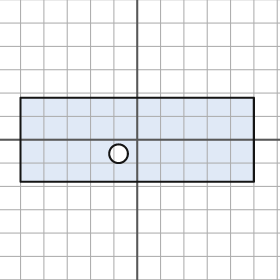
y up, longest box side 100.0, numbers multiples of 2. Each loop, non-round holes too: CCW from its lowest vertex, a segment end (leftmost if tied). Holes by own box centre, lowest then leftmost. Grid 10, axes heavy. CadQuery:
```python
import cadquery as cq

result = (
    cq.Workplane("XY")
    .moveTo(-50.0, -18.0)
    .lineTo(50.0, -18.0)
    .lineTo(50.0, 18.0)
    .lineTo(-50.0, 18.0)
    .close()
    .moveTo(-8.0, -6.0)
    .circle(4.0)
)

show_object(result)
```